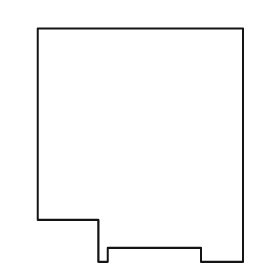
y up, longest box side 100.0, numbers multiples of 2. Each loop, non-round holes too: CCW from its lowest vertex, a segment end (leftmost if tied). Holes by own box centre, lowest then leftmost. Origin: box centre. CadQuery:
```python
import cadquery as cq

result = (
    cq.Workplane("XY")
    .moveTo(-18.0, -50.0)
    .lineTo(-14.0, -50.0)
    .lineTo(-14.0, -44.0)
    .lineTo(26.0, -44.0)
    .lineTo(26.0, -50.0)
    .lineTo(44.0, -50.0)
    .lineTo(44.0, 50.0)
    .lineTo(-44.0, 50.0)
    .lineTo(-44.0, -32.0)
    .lineTo(-18.0, -32.0)
    .close()
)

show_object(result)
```